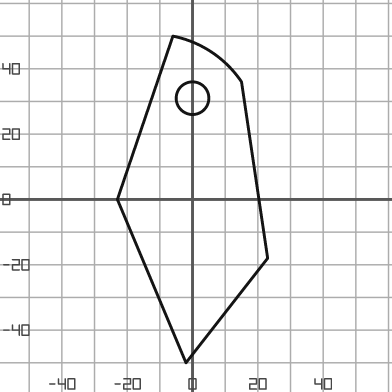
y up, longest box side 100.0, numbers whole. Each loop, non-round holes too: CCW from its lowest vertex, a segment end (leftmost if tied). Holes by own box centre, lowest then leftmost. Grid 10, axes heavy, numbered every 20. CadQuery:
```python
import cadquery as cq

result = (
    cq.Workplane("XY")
    .moveTo(-2.0, -50.0)
    .lineTo(23.0, -18.0)
    .lineTo(15.0, 36.0)
    .threePointArc((6.0, 45.0), (-6.0, 50.0))
    .lineTo(-23.0, 0.0)
    .close()
    .moveTo(0.0, 31.0)
    .circle(5.0)
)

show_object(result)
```